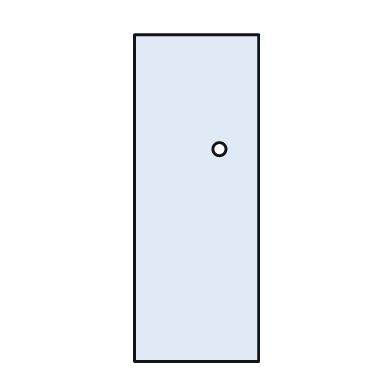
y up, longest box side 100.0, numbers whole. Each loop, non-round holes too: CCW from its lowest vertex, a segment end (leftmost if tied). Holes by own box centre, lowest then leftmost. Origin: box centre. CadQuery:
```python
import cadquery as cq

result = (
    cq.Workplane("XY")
    .moveTo(-19.0, -50.0)
    .lineTo(19.0, -50.0)
    .lineTo(19.0, 50.0)
    .lineTo(-19.0, 50.0)
    .close()
    .moveTo(7.0, 15.0)
    .circle(2.0)
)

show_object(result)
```